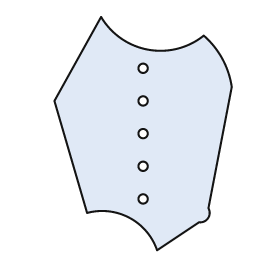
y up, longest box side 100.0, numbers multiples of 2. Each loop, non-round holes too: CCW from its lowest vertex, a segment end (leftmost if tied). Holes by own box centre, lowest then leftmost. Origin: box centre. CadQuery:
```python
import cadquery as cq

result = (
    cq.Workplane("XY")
    .moveTo(6.0, -50.0)
    .lineTo(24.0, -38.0)
    .threePointArc((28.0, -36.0), (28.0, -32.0))
    .lineTo(38.0, 20.0)
    .threePointArc((34.0, 32.0), (26.0, 42.0))
    .threePointArc((2.0, 36.0), (-18.0, 50.0))
    .lineTo(-38.0, 14.0)
    .lineTo(-24.0, -34.0)
    .threePointArc((-6.0, -36.0), (6.0, -50.0))
    .close()
    .moveTo(0.0, -28.0)
    .circle(2.0)
    .moveTo(0.0, -14.0)
    .circle(2.0)
    .moveTo(0.0, 0.0)
    .circle(2.0)
    .moveTo(0.0, 14.0)
    .circle(2.0)
    .moveTo(0.0, 28.0)
    .circle(2.0)
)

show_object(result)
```